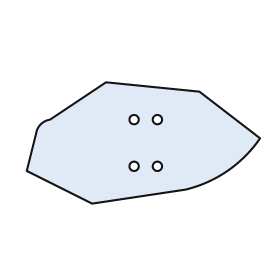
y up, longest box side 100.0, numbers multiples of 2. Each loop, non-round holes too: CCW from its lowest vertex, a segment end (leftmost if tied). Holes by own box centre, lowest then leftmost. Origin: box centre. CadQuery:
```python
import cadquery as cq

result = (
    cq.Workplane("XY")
    .moveTo(-22.0, -26.0)
    .lineTo(18.0, -20.0)
    .threePointArc((36.0, -12.0), (50.0, 2.0))
    .lineTo(24.0, 22.0)
    .lineTo(-16.0, 26.0)
    .lineTo(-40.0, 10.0)
    .threePointArc((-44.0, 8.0), (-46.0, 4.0))
    .lineTo(-50.0, -12.0)
    .close()
    .moveTo(-4.0, -10.0)
    .circle(2.0)
    .moveTo(6.0, -10.0)
    .circle(2.0)
    .moveTo(-4.0, 10.0)
    .circle(2.0)
    .moveTo(6.0, 10.0)
    .circle(2.0)
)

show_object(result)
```